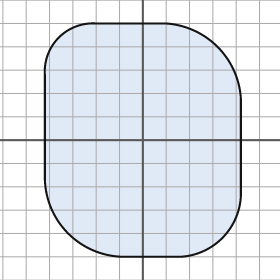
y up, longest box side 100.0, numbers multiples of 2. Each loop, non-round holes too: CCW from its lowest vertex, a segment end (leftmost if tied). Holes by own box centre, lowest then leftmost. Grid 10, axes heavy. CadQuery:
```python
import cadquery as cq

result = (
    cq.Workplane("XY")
    .moveTo(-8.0, -50.0)
    .lineTo(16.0, -50.0)
    .threePointArc((34.0, -42.0), (42.0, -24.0))
    .lineTo(42.0, 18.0)
    .threePointArc((32.0, 40.0), (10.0, 50.0))
    .lineTo(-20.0, 50.0)
    .threePointArc((-36.0, 44.0), (-42.0, 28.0))
    .lineTo(-42.0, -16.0)
    .threePointArc((-32.0, -40.0), (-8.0, -50.0))
    .close()
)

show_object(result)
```